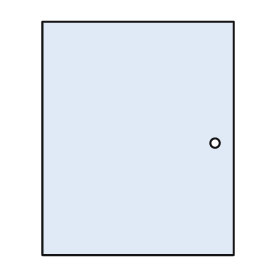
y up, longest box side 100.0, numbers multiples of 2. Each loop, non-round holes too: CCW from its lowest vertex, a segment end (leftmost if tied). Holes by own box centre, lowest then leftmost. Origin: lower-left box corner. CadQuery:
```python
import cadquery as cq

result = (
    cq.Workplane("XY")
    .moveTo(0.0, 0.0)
    .lineTo(82.0, 0.0)
    .lineTo(82.0, 100.0)
    .lineTo(0.0, 100.0)
    .close()
    .moveTo(74.0, 48.0)
    .circle(2.0)
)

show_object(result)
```